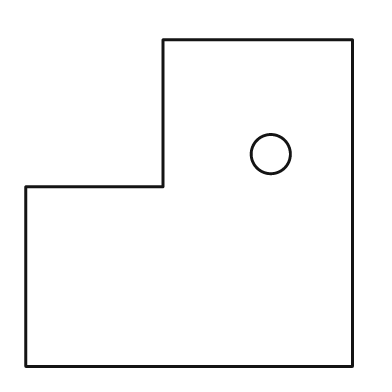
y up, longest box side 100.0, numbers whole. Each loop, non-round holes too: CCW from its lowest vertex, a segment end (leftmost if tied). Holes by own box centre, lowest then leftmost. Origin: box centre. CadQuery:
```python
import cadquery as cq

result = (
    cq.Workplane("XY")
    .moveTo(-50.0, -50.0)
    .lineTo(50.0, -50.0)
    .lineTo(50.0, 50.0)
    .lineTo(-8.0, 50.0)
    .lineTo(-8.0, 5.0)
    .lineTo(-50.0, 5.0)
    .close()
    .moveTo(25.0, 15.0)
    .circle(6.0)
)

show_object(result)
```